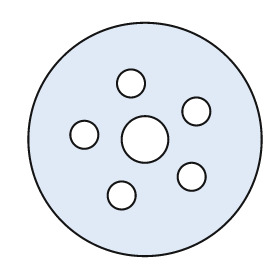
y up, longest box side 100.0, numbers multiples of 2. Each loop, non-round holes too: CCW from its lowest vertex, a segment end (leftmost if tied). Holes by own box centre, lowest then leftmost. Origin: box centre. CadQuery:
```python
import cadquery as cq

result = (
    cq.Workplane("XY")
    .moveTo(0.0, 0.0)
    .circle(50.0)
    .moveTo(-10.0, -24.0)
    .circle(6.0)
    .moveTo(20.0, -16.0)
    .circle(6.0)
    .moveTo(0.0, 0.0)
    .circle(10.0)
    .moveTo(-26.0, 2.0)
    .circle(6.0)
    .moveTo(22.0, 12.0)
    .circle(6.0)
    .moveTo(-6.0, 24.0)
    .circle(6.0)
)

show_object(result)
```